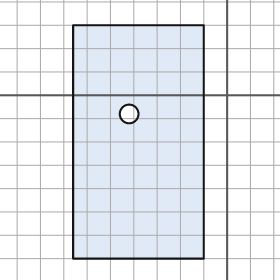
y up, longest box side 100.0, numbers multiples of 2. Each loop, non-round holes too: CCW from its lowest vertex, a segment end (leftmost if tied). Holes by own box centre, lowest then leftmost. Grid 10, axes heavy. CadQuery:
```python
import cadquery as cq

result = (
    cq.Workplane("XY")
    .moveTo(-66.0, -70.0)
    .lineTo(-10.0, -70.0)
    .lineTo(-10.0, 30.0)
    .lineTo(-66.0, 30.0)
    .close()
    .moveTo(-42.0, -8.0)
    .circle(4.0)
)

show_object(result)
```